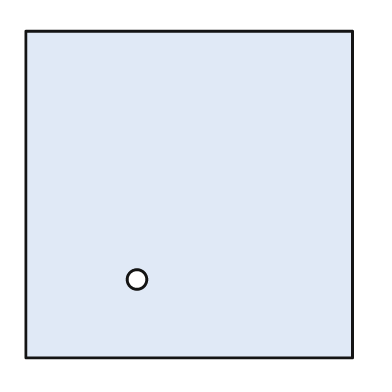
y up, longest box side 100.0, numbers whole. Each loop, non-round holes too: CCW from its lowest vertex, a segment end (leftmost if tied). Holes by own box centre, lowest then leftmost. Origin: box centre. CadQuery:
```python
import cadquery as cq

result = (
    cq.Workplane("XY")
    .moveTo(-50.0, -50.0)
    .lineTo(50.0, -50.0)
    .lineTo(50.0, 50.0)
    .lineTo(-50.0, 50.0)
    .close()
    .moveTo(-16.0, -26.0)
    .circle(3.0)
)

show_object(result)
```